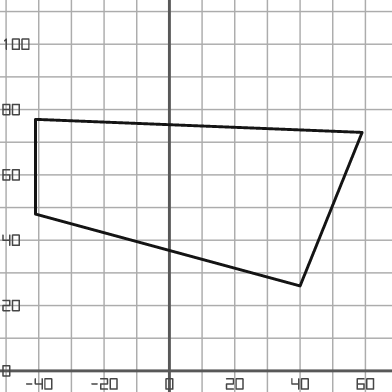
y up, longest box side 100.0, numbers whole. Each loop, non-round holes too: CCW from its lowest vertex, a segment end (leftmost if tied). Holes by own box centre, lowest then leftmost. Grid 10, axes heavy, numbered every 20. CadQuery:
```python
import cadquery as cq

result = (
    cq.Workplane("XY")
    .moveTo(40.0, 26.0)
    .lineTo(59.0, 73.0)
    .lineTo(-41.0, 77.0)
    .lineTo(-41.0, 48.0)
    .close()
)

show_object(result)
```